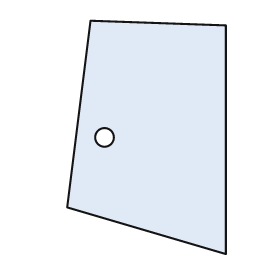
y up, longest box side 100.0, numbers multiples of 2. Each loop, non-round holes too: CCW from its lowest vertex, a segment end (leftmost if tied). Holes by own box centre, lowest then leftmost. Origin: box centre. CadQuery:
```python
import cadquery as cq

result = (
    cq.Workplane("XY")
    .moveTo(34.0, -50.0)
    .lineTo(34.0, 48.0)
    .lineTo(-24.0, 50.0)
    .lineTo(-34.0, -30.0)
    .close()
    .moveTo(-18.0, 0.0)
    .circle(4.0)
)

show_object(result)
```